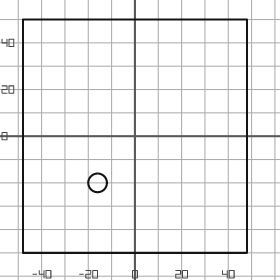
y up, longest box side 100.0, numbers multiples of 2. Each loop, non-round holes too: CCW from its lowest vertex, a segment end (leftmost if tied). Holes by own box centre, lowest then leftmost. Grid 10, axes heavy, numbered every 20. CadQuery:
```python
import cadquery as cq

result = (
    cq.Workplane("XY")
    .moveTo(-48.0, -50.0)
    .lineTo(48.0, -50.0)
    .lineTo(48.0, 50.0)
    .lineTo(-48.0, 50.0)
    .close()
    .moveTo(-16.0, -20.0)
    .circle(4.0)
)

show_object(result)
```